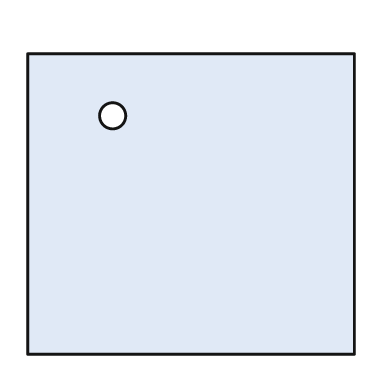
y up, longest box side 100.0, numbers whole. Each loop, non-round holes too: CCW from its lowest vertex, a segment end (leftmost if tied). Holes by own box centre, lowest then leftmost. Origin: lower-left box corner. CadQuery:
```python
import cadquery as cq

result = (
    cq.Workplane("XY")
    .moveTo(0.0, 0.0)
    .lineTo(100.0, 0.0)
    .lineTo(100.0, 92.0)
    .lineTo(0.0, 92.0)
    .close()
    .moveTo(26.0, 73.0)
    .circle(4.0)
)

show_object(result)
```